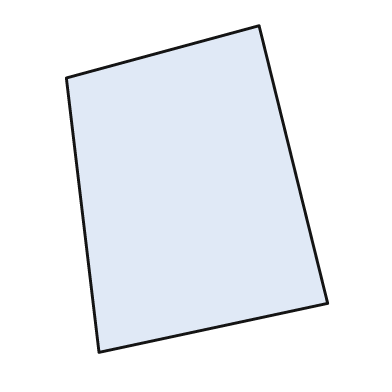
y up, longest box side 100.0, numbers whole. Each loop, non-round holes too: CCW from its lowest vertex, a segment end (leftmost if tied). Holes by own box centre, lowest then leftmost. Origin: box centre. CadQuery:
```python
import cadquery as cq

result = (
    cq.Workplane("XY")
    .moveTo(-30.0, -50.0)
    .lineTo(40.0, -35.0)
    .lineTo(19.0, 50.0)
    .lineTo(-40.0, 34.0)
    .close()
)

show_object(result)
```